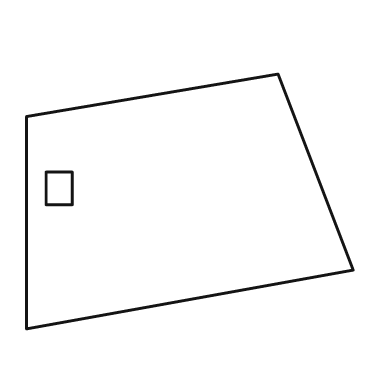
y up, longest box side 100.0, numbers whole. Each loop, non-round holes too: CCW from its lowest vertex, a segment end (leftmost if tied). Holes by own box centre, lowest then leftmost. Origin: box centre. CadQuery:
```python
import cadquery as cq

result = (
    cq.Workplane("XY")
    .moveTo(-50.0, -39.0)
    .lineTo(50.0, -21.0)
    .lineTo(27.0, 39.0)
    .lineTo(-50.0, 26.0)
    .close()
    .moveTo(-44.0, -1.0)
    .lineTo(-36.0, -1.0)
    .lineTo(-36.0, 9.0)
    .lineTo(-44.0, 9.0)
    .close()
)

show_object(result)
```